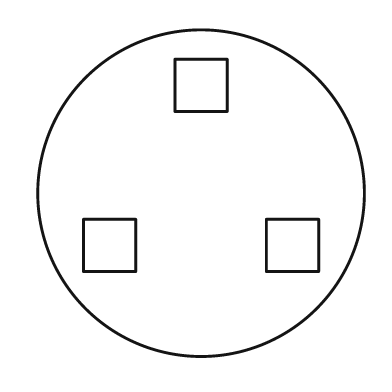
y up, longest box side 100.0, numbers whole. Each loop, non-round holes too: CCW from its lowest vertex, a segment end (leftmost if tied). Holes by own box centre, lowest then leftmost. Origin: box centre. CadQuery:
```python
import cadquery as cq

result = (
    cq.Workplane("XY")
    .moveTo(0.0, 0.0)
    .circle(50.0)
    .moveTo(-36.0, -24.0)
    .lineTo(-20.0, -24.0)
    .lineTo(-20.0, -8.0)
    .lineTo(-36.0, -8.0)
    .close()
    .moveTo(20.0, -24.0)
    .lineTo(36.0, -24.0)
    .lineTo(36.0, -8.0)
    .lineTo(20.0, -8.0)
    .close()
    .moveTo(-8.0, 25.0)
    .lineTo(8.0, 25.0)
    .lineTo(8.0, 41.0)
    .lineTo(-8.0, 41.0)
    .close()
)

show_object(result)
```